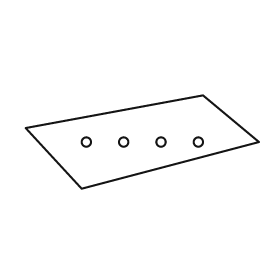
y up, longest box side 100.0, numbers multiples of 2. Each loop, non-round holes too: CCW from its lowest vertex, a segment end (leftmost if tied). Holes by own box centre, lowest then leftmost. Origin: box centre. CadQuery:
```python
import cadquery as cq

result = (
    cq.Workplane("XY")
    .moveTo(-26.0, -20.0)
    .lineTo(50.0, 0.0)
    .lineTo(26.0, 20.0)
    .lineTo(-50.0, 6.0)
    .close()
    .moveTo(-24.0, 0.0)
    .circle(2.0)
    .moveTo(-8.0, 0.0)
    .circle(2.0)
    .moveTo(8.0, 0.0)
    .circle(2.0)
    .moveTo(24.0, 0.0)
    .circle(2.0)
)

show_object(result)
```